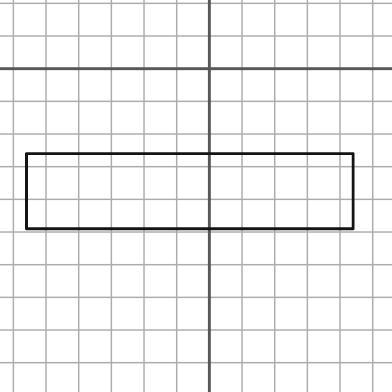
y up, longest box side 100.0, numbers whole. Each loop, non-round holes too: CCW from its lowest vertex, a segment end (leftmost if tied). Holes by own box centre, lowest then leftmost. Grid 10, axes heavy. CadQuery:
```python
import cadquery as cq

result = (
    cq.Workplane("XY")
    .moveTo(-56.0, -49.0)
    .lineTo(44.0, -49.0)
    .lineTo(44.0, -26.0)
    .lineTo(-56.0, -26.0)
    .close()
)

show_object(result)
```